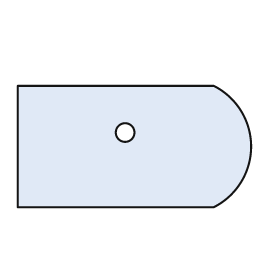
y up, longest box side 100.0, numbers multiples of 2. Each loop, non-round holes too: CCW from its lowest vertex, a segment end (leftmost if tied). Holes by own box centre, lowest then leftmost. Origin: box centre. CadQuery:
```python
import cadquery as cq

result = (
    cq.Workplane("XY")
    .moveTo(-50.0, -26.0)
    .lineTo(34.0, -26.0)
    .threePointArc((50.0, 0.0), (34.0, 26.0))
    .lineTo(-50.0, 26.0)
    .close()
    .moveTo(-4.0, 6.0)
    .circle(4.0)
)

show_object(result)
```